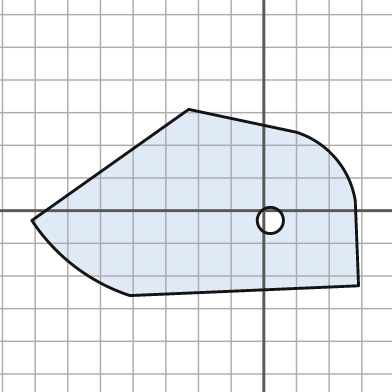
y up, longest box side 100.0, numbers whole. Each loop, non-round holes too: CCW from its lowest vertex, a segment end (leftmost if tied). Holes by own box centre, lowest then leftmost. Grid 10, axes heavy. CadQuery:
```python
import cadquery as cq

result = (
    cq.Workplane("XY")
    .moveTo(-41.0, -26.0)
    .lineTo(29.0, -23.0)
    .lineTo(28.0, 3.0)
    .threePointArc((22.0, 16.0), (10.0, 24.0))
    .lineTo(-23.0, 31.0)
    .lineTo(-71.0, -3.0)
    .threePointArc((-58.0, -17.0), (-41.0, -26.0))
    .close()
    .moveTo(2.0, -3.0)
    .circle(4.0)
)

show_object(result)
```